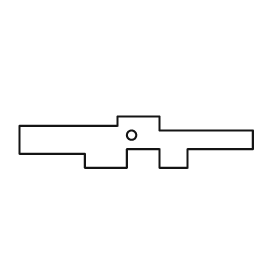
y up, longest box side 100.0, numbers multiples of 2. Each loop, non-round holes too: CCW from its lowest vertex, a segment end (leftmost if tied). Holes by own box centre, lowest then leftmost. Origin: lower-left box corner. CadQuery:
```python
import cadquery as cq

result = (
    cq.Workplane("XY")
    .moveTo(28.0, 0.0)
    .lineTo(46.0, 0.0)
    .lineTo(46.0, 8.0)
    .lineTo(60.0, 8.0)
    .lineTo(60.0, 0.0)
    .lineTo(72.0, 0.0)
    .lineTo(72.0, 8.0)
    .lineTo(100.0, 8.0)
    .lineTo(100.0, 16.0)
    .lineTo(60.0, 16.0)
    .lineTo(60.0, 22.0)
    .lineTo(42.0, 22.0)
    .lineTo(42.0, 18.0)
    .lineTo(0.0, 18.0)
    .lineTo(0.0, 6.0)
    .lineTo(28.0, 6.0)
    .close()
    .moveTo(48.0, 14.0)
    .circle(2.0)
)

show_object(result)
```